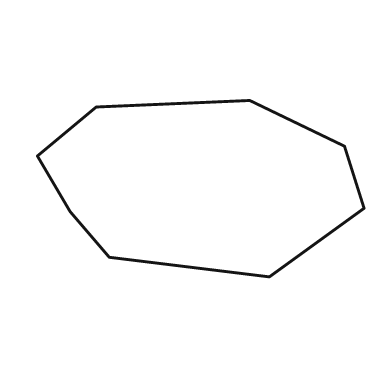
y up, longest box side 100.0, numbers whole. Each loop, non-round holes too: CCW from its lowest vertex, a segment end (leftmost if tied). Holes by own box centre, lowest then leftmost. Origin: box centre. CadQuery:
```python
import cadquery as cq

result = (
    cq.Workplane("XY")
    .moveTo(21.0, -27.0)
    .lineTo(50.0, -6.0)
    .lineTo(44.0, 13.0)
    .lineTo(15.0, 27.0)
    .lineTo(-32.0, 25.0)
    .lineTo(-50.0, 10.0)
    .lineTo(-40.0, -7.0)
    .lineTo(-28.0, -21.0)
    .close()
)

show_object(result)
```